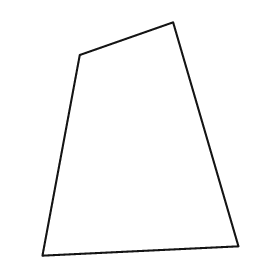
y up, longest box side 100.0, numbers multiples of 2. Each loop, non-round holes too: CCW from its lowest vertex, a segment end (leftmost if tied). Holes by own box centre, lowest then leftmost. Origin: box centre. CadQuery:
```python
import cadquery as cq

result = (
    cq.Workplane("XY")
    .moveTo(-42.0, -50.0)
    .lineTo(42.0, -46.0)
    .lineTo(14.0, 50.0)
    .lineTo(-26.0, 36.0)
    .close()
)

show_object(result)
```